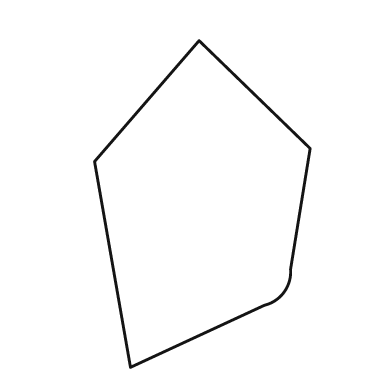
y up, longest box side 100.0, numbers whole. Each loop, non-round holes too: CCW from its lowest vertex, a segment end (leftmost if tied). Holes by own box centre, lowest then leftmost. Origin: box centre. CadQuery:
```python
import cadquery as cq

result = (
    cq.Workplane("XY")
    .moveTo(-22.0, -50.0)
    .lineTo(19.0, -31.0)
    .threePointArc((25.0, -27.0), (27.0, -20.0))
    .lineTo(33.0, 17.0)
    .lineTo(-1.0, 50.0)
    .lineTo(-33.0, 13.0)
    .close()
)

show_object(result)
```